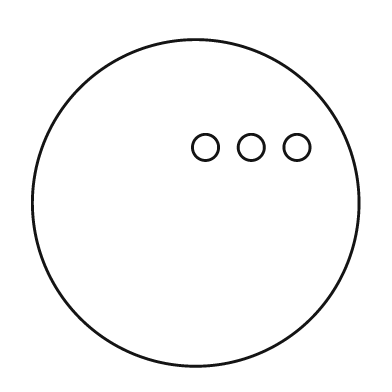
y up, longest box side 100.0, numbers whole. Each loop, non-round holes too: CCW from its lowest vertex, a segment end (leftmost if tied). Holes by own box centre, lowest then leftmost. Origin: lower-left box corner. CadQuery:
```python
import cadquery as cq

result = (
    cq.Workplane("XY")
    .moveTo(50.0, 50.0)
    .circle(50.0)
    .moveTo(53.0, 67.0)
    .circle(4.0)
    .moveTo(67.0, 67.0)
    .circle(4.0)
    .moveTo(81.0, 67.0)
    .circle(4.0)
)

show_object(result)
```